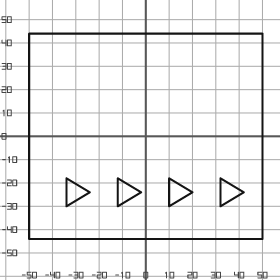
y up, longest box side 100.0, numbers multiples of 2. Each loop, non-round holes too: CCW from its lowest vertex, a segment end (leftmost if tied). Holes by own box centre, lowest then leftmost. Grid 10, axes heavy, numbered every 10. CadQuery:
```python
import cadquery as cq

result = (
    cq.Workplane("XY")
    .moveTo(-50.0, -44.0)
    .lineTo(50.0, -44.0)
    .lineTo(50.0, 44.0)
    .lineTo(-50.0, 44.0)
    .close()
    .moveTo(-34.0, -30.0)
    .lineTo(-24.0, -24.0)
    .lineTo(-34.0, -18.0)
    .close()
    .moveTo(-12.0, -30.0)
    .lineTo(-2.0, -24.0)
    .lineTo(-12.0, -18.0)
    .close()
    .moveTo(10.0, -30.0)
    .lineTo(20.0, -24.0)
    .lineTo(10.0, -18.0)
    .close()
    .moveTo(32.0, -30.0)
    .lineTo(42.0, -24.0)
    .lineTo(32.0, -18.0)
    .close()
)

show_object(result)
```